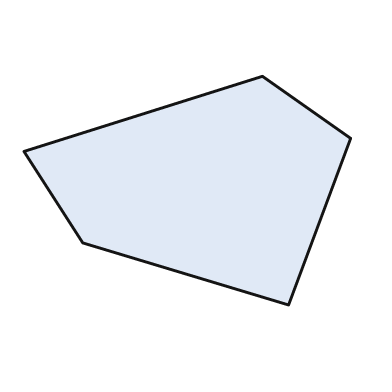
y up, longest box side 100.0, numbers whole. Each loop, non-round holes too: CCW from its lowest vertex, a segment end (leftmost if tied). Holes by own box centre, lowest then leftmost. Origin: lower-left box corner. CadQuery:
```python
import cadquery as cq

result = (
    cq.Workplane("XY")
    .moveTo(81.0, 0.0)
    .lineTo(100.0, 51.0)
    .lineTo(73.0, 70.0)
    .lineTo(0.0, 47.0)
    .lineTo(18.0, 19.0)
    .close()
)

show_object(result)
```